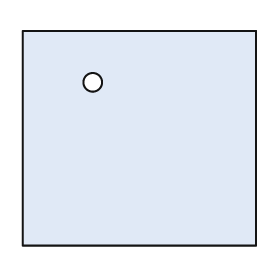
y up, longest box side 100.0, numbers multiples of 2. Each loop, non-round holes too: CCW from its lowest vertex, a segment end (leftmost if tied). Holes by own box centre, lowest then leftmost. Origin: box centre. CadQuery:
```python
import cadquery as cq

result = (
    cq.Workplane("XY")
    .moveTo(-50.0, -46.0)
    .lineTo(50.0, -46.0)
    .lineTo(50.0, 46.0)
    .lineTo(-50.0, 46.0)
    .close()
    .moveTo(-20.0, 24.0)
    .circle(4.0)
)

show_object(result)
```